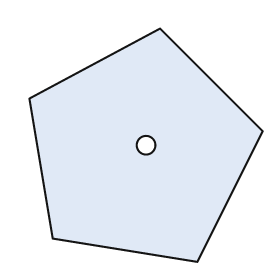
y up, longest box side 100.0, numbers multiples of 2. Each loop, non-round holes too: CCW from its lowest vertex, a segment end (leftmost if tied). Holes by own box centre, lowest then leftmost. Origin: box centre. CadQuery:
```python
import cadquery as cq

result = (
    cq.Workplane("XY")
    .moveTo(22.0, -50.0)
    .lineTo(50.0, 6.0)
    .lineTo(6.0, 50.0)
    .lineTo(-50.0, 20.0)
    .lineTo(-40.0, -40.0)
    .close()
    .moveTo(0.0, 0.0)
    .circle(4.0)
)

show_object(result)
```